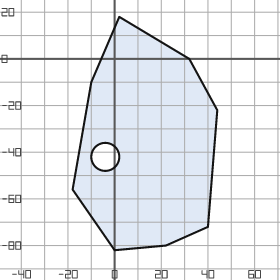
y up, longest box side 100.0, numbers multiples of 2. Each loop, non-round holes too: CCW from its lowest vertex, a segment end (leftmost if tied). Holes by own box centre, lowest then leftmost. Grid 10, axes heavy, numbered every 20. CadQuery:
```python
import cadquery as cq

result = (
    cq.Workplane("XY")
    .moveTo(0.0, -82.0)
    .lineTo(22.0, -80.0)
    .lineTo(40.0, -72.0)
    .lineTo(44.0, -22.0)
    .lineTo(32.0, 0.0)
    .lineTo(2.0, 18.0)
    .lineTo(-10.0, -10.0)
    .lineTo(-18.0, -56.0)
    .close()
    .moveTo(-4.0, -42.0)
    .circle(6.0)
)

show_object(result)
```